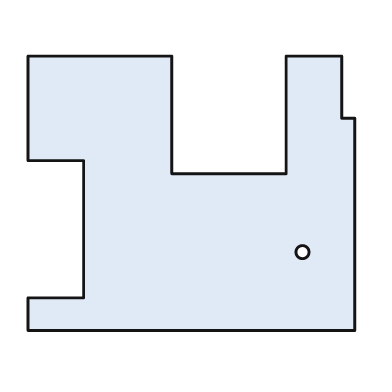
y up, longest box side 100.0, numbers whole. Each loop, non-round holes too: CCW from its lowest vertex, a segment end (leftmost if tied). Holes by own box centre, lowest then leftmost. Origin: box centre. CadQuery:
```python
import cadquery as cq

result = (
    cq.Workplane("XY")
    .moveTo(-50.0, -42.0)
    .lineTo(50.0, -42.0)
    .lineTo(50.0, 23.0)
    .lineTo(46.0, 23.0)
    .lineTo(46.0, 42.0)
    .lineTo(29.0, 42.0)
    .lineTo(29.0, 6.0)
    .lineTo(-6.0, 6.0)
    .lineTo(-6.0, 42.0)
    .lineTo(-50.0, 42.0)
    .lineTo(-50.0, 10.0)
    .lineTo(-33.0, 10.0)
    .lineTo(-33.0, -32.0)
    .lineTo(-50.0, -32.0)
    .close()
    .moveTo(34.0, -18.0)
    .circle(2.0)
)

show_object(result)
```